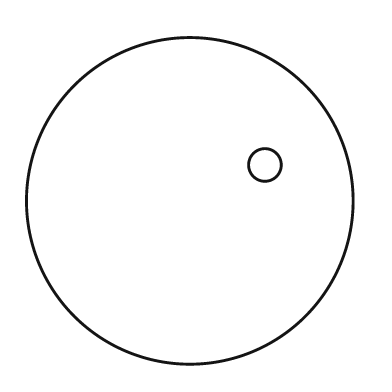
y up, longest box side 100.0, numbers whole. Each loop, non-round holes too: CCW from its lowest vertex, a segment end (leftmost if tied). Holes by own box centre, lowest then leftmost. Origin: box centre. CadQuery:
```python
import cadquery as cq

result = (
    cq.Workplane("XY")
    .moveTo(0.0, 0.0)
    .circle(50.0)
    .moveTo(23.0, 11.0)
    .circle(5.0)
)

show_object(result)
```